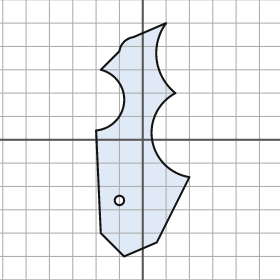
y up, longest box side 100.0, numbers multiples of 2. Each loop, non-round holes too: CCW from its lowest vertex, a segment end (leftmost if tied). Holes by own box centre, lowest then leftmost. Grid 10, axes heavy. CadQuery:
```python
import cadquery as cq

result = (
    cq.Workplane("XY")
    .moveTo(-8.0, -50.0)
    .lineTo(6.0, -44.0)
    .lineTo(20.0, -16.0)
    .threePointArc((4.0, 0.0), (14.0, 20.0))
    .threePointArc((6.0, 34.0), (10.0, 50.0))
    .lineTo(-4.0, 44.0)
    .threePointArc((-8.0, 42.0), (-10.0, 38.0))
    .lineTo(-18.0, 30.0)
    .threePointArc((-8.0, 16.0), (-20.0, 4.0))
    .lineTo(-18.0, -40.0)
    .close()
    .moveTo(-10.0, -26.0)
    .circle(2.0)
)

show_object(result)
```